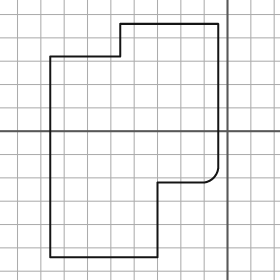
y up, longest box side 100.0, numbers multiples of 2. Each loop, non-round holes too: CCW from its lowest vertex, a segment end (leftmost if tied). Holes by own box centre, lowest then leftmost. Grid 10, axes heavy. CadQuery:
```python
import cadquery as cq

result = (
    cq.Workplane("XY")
    .moveTo(-76.0, -54.0)
    .lineTo(-30.0, -54.0)
    .lineTo(-30.0, -22.0)
    .lineTo(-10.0, -22.0)
    .threePointArc((-6.0, -20.0), (-4.0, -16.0))
    .lineTo(-4.0, 46.0)
    .lineTo(-46.0, 46.0)
    .lineTo(-46.0, 32.0)
    .lineTo(-76.0, 32.0)
    .close()
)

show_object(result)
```